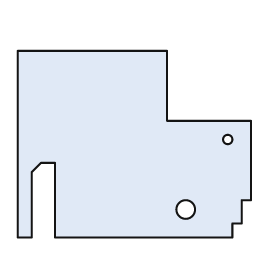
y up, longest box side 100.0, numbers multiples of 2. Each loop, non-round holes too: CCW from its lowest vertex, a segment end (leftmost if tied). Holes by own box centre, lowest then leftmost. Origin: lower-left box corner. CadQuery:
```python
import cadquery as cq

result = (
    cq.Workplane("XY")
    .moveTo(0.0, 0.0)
    .lineTo(6.0, 0.0)
    .lineTo(6.0, 28.0)
    .lineTo(10.0, 32.0)
    .lineTo(16.0, 32.0)
    .lineTo(16.0, 0.0)
    .lineTo(92.0, 0.0)
    .lineTo(92.0, 6.0)
    .lineTo(96.0, 6.0)
    .lineTo(96.0, 16.0)
    .lineTo(100.0, 16.0)
    .lineTo(100.0, 50.0)
    .lineTo(64.0, 50.0)
    .lineTo(64.0, 80.0)
    .lineTo(0.0, 80.0)
    .close()
    .moveTo(72.0, 12.0)
    .circle(4.0)
    .moveTo(90.0, 42.0)
    .circle(2.0)
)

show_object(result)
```